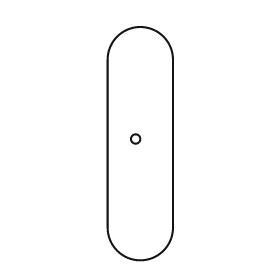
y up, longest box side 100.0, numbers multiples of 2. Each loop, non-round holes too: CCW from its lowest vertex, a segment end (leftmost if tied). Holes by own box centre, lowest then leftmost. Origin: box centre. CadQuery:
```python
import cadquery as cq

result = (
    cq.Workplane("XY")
    .moveTo(-14.0, -36.0)
    .threePointArc((0.0, -50.0), (14.0, -36.0))
    .lineTo(14.0, 36.0)
    .threePointArc((0.0, 50.0), (-14.0, 36.0))
    .close()
    .moveTo(-2.0, 2.0)
    .circle(2.0)
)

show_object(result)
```